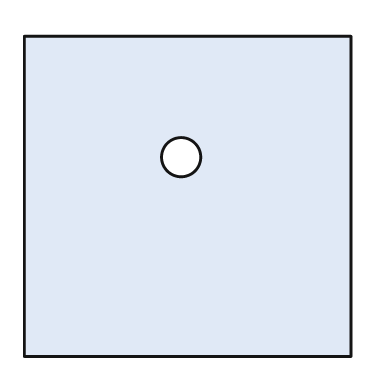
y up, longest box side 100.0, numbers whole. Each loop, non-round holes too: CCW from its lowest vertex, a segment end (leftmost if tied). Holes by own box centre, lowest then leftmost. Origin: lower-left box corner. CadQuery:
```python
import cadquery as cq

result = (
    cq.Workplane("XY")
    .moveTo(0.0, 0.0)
    .lineTo(100.0, 0.0)
    .lineTo(100.0, 98.0)
    .lineTo(0.0, 98.0)
    .close()
    .moveTo(48.0, 61.0)
    .circle(6.0)
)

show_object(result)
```